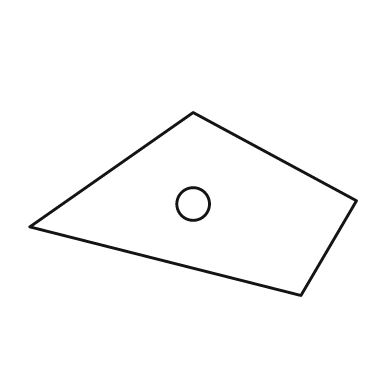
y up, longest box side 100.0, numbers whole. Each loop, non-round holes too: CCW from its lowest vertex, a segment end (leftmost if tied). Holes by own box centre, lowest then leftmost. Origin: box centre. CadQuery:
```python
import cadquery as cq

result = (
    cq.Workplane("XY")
    .moveTo(33.0, -28.0)
    .lineTo(50.0, 1.0)
    .lineTo(0.0, 28.0)
    .lineTo(-50.0, -7.0)
    .close()
    .moveTo(0.0, 0.0)
    .circle(5.0)
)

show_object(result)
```